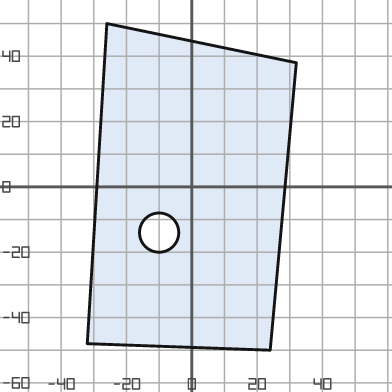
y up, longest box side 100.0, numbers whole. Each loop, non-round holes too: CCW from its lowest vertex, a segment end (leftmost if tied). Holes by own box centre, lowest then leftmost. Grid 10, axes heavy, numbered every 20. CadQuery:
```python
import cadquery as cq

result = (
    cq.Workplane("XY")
    .moveTo(24.0, -50.0)
    .lineTo(32.0, 38.0)
    .lineTo(-26.0, 50.0)
    .lineTo(-32.0, -48.0)
    .close()
    .moveTo(-10.0, -14.0)
    .circle(6.0)
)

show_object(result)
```